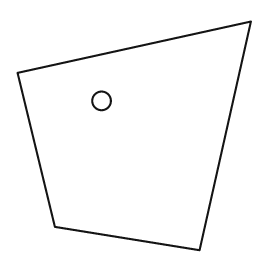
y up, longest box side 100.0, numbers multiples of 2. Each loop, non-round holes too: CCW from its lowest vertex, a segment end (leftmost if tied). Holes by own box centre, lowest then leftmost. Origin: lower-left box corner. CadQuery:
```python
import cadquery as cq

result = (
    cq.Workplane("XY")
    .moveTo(78.0, 0.0)
    .lineTo(100.0, 98.0)
    .lineTo(0.0, 76.0)
    .lineTo(16.0, 10.0)
    .close()
    .moveTo(36.0, 64.0)
    .circle(4.0)
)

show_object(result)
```